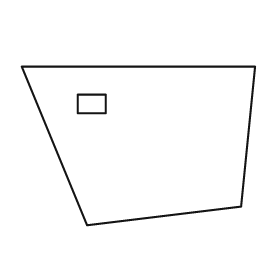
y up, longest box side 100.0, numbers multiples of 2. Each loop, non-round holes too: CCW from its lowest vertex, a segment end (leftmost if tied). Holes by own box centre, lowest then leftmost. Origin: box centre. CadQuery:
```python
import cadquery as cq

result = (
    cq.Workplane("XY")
    .moveTo(-22.0, -34.0)
    .lineTo(44.0, -26.0)
    .lineTo(50.0, 34.0)
    .lineTo(-50.0, 34.0)
    .close()
    .moveTo(-26.0, 14.0)
    .lineTo(-14.0, 14.0)
    .lineTo(-14.0, 22.0)
    .lineTo(-26.0, 22.0)
    .close()
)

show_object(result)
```